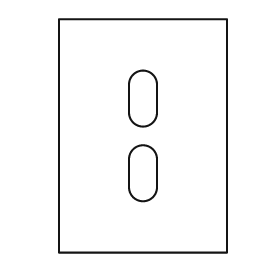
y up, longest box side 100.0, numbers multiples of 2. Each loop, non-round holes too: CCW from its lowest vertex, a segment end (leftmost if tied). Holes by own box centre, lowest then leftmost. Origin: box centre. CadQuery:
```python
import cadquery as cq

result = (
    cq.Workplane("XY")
    .moveTo(-36.0, -50.0)
    .lineTo(36.0, -50.0)
    .lineTo(36.0, 50.0)
    .lineTo(-36.0, 50.0)
    .close()
    .moveTo(-6.0, -22.0)
    .threePointArc((0.0, -28.0), (6.0, -22.0))
    .lineTo(6.0, -10.0)
    .threePointArc((0.0, -4.0), (-6.0, -10.0))
    .close()
    .moveTo(-6.0, 10.0)
    .threePointArc((0.0, 4.0), (6.0, 10.0))
    .lineTo(6.0, 22.0)
    .threePointArc((0.0, 28.0), (-6.0, 22.0))
    .close()
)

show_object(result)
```